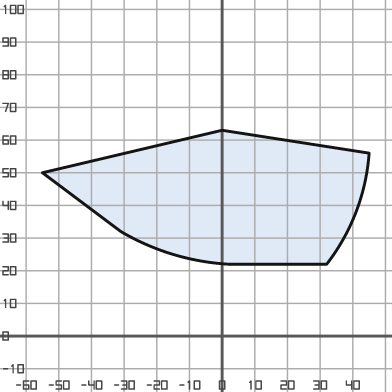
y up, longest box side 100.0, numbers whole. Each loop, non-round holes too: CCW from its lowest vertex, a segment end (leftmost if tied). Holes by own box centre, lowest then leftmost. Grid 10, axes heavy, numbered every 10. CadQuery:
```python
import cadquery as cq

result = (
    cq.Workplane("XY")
    .moveTo(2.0, 22.0)
    .lineTo(32.0, 22.0)
    .threePointArc((41.0, 38.0), (45.0, 56.0))
    .lineTo(0.0, 63.0)
    .lineTo(-55.0, 50.0)
    .lineTo(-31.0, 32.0)
    .threePointArc((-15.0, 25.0), (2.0, 22.0))
    .close()
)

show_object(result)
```